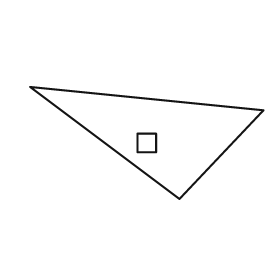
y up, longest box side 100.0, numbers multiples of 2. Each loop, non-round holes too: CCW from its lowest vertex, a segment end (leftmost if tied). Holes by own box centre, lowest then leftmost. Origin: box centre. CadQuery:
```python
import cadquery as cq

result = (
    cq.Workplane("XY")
    .moveTo(14.0, -24.0)
    .lineTo(50.0, 14.0)
    .lineTo(-50.0, 24.0)
    .close()
    .moveTo(-4.0, -4.0)
    .lineTo(4.0, -4.0)
    .lineTo(4.0, 4.0)
    .lineTo(-4.0, 4.0)
    .close()
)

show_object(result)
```